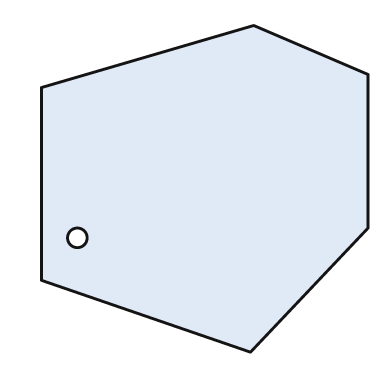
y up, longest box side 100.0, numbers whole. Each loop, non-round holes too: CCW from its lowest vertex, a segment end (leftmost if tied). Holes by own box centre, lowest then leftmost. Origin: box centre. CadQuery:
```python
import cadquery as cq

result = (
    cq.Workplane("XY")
    .moveTo(14.0, -50.0)
    .lineTo(50.0, -12.0)
    .lineTo(50.0, 35.0)
    .lineTo(15.0, 50.0)
    .lineTo(-50.0, 31.0)
    .lineTo(-50.0, -28.0)
    .close()
    .moveTo(-39.0, -15.0)
    .circle(3.0)
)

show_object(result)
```